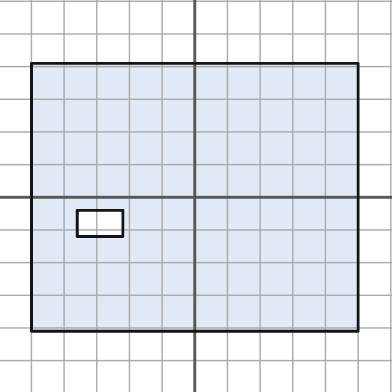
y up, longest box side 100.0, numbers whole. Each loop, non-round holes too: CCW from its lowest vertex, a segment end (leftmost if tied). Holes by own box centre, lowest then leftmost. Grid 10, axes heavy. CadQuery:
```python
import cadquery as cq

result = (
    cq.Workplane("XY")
    .moveTo(-50.0, -41.0)
    .lineTo(50.0, -41.0)
    .lineTo(50.0, 41.0)
    .lineTo(-50.0, 41.0)
    .close()
    .moveTo(-36.0, -12.0)
    .lineTo(-22.0, -12.0)
    .lineTo(-22.0, -4.0)
    .lineTo(-36.0, -4.0)
    .close()
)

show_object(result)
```